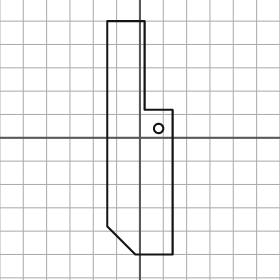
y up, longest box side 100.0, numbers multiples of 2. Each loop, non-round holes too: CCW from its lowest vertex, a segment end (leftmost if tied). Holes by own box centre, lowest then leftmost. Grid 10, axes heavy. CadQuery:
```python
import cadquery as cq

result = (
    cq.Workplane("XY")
    .moveTo(-2.0, -50.0)
    .lineTo(14.0, -50.0)
    .lineTo(14.0, 12.0)
    .lineTo(2.0, 12.0)
    .lineTo(2.0, 50.0)
    .lineTo(-14.0, 50.0)
    .lineTo(-14.0, -38.0)
    .close()
    .moveTo(8.0, 4.0)
    .circle(2.0)
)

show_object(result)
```